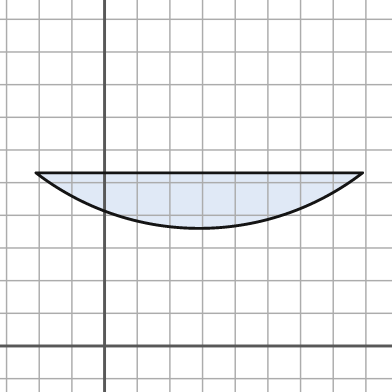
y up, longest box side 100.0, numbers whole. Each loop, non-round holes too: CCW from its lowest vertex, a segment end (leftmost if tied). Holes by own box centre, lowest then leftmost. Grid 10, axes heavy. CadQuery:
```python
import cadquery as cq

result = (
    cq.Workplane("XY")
    .moveTo(-21.0, 53.0)
    .threePointArc((29.0, 36.0), (79.0, 53.0))
    .close()
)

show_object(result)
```